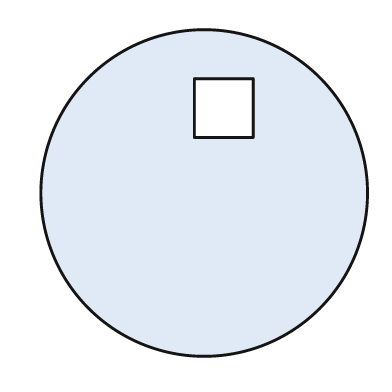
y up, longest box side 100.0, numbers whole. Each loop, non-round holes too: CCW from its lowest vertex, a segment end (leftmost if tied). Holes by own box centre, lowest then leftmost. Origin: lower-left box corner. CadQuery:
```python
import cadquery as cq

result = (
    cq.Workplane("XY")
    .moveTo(50.0, 50.0)
    .circle(50.0)
    .moveTo(47.0, 67.0)
    .lineTo(65.0, 67.0)
    .lineTo(65.0, 85.0)
    .lineTo(47.0, 85.0)
    .close()
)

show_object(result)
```